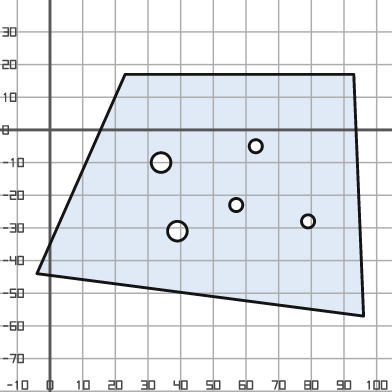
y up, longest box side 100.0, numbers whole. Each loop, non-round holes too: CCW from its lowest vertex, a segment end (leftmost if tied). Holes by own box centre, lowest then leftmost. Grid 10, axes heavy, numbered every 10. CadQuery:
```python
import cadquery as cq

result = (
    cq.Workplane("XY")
    .moveTo(96.0, -57.0)
    .lineTo(93.0, 17.0)
    .lineTo(23.0, 17.0)
    .lineTo(-4.0, -44.0)
    .close()
    .moveTo(39.0, -31.0)
    .circle(3.0)
    .moveTo(79.0, -28.0)
    .circle(2.0)
    .moveTo(57.0, -23.0)
    .circle(2.0)
    .moveTo(34.0, -10.0)
    .circle(3.0)
    .moveTo(63.0, -5.0)
    .circle(2.0)
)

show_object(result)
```